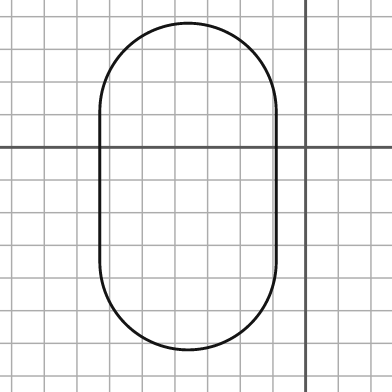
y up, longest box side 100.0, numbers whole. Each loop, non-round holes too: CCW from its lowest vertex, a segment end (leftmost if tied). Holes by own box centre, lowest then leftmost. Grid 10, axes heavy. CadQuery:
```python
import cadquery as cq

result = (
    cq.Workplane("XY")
    .moveTo(-63.0, -35.0)
    .threePointArc((-36.0, -62.0), (-9.0, -35.0))
    .lineTo(-9.0, 11.0)
    .threePointArc((-36.0, 38.0), (-63.0, 11.0))
    .close()
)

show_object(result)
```